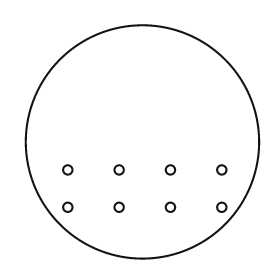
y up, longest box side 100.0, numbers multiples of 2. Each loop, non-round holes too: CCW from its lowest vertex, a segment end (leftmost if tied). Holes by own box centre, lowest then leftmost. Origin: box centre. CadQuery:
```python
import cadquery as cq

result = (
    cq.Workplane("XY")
    .moveTo(0.0, 0.0)
    .circle(50.0)
    .moveTo(-32.0, -28.0)
    .circle(2.0)
    .moveTo(-10.0, -28.0)
    .circle(2.0)
    .moveTo(12.0, -28.0)
    .circle(2.0)
    .moveTo(34.0, -28.0)
    .circle(2.0)
    .moveTo(-32.0, -12.0)
    .circle(2.0)
    .moveTo(-10.0, -12.0)
    .circle(2.0)
    .moveTo(12.0, -12.0)
    .circle(2.0)
    .moveTo(34.0, -12.0)
    .circle(2.0)
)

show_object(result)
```